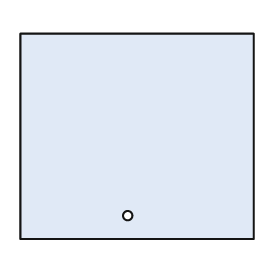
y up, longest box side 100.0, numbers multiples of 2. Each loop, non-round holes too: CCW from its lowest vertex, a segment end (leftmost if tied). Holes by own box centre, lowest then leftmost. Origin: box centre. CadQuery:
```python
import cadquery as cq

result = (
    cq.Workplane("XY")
    .moveTo(-50.0, -44.0)
    .lineTo(50.0, -44.0)
    .lineTo(50.0, 44.0)
    .lineTo(-50.0, 44.0)
    .close()
    .moveTo(-4.0, -34.0)
    .circle(2.0)
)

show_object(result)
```